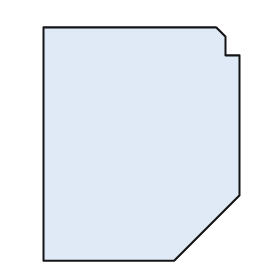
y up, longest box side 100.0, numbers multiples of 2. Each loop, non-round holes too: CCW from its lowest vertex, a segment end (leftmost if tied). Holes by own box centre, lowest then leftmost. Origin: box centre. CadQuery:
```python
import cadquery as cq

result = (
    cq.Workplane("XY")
    .moveTo(-42.0, -50.0)
    .lineTo(14.0, -50.0)
    .lineTo(42.0, -22.0)
    .lineTo(42.0, 38.0)
    .lineTo(36.0, 38.0)
    .lineTo(36.0, 46.0)
    .lineTo(32.0, 50.0)
    .lineTo(-42.0, 50.0)
    .close()
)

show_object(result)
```